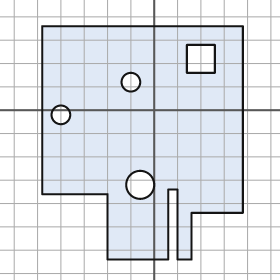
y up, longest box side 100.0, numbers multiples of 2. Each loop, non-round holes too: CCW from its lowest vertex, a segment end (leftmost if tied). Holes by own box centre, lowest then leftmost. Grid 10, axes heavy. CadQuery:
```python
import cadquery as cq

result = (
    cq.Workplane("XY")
    .moveTo(-20.0, -64.0)
    .lineTo(6.0, -64.0)
    .lineTo(6.0, -34.0)
    .lineTo(10.0, -34.0)
    .lineTo(10.0, -64.0)
    .lineTo(16.0, -64.0)
    .lineTo(16.0, -44.0)
    .lineTo(38.0, -44.0)
    .lineTo(38.0, 36.0)
    .lineTo(-48.0, 36.0)
    .lineTo(-48.0, -36.0)
    .lineTo(-20.0, -36.0)
    .close()
    .moveTo(-6.0, -32.0)
    .circle(6.0)
    .moveTo(-40.0, -2.0)
    .circle(4.0)
    .moveTo(-10.0, 12.0)
    .circle(4.0)
    .moveTo(14.0, 16.0)
    .lineTo(26.0, 16.0)
    .lineTo(26.0, 28.0)
    .lineTo(14.0, 28.0)
    .close()
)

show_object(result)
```